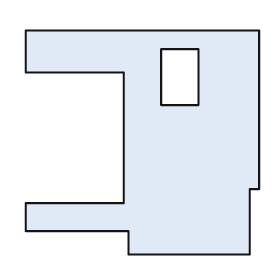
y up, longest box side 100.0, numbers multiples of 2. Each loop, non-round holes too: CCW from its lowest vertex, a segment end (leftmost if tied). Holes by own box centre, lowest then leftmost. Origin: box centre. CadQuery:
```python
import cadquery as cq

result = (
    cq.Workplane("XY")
    .moveTo(-6.0, -48.0)
    .lineTo(46.0, -48.0)
    .lineTo(46.0, -20.0)
    .lineTo(50.0, -20.0)
    .lineTo(50.0, 48.0)
    .lineTo(-50.0, 48.0)
    .lineTo(-50.0, 30.0)
    .lineTo(-8.0, 30.0)
    .lineTo(-8.0, -26.0)
    .lineTo(-50.0, -26.0)
    .lineTo(-50.0, -38.0)
    .lineTo(-6.0, -38.0)
    .close()
    .moveTo(8.0, 16.0)
    .lineTo(24.0, 16.0)
    .lineTo(24.0, 40.0)
    .lineTo(8.0, 40.0)
    .close()
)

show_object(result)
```